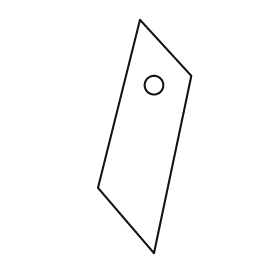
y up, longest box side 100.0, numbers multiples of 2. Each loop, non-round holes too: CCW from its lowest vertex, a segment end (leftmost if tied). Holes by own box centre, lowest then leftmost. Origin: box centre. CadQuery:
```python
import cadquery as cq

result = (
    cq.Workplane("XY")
    .moveTo(4.0, -50.0)
    .lineTo(20.0, 26.0)
    .lineTo(-2.0, 50.0)
    .lineTo(-20.0, -22.0)
    .close()
    .moveTo(4.0, 22.0)
    .circle(4.0)
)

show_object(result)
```